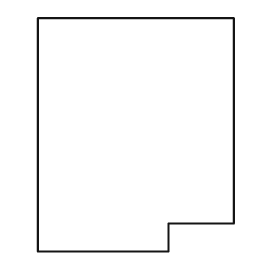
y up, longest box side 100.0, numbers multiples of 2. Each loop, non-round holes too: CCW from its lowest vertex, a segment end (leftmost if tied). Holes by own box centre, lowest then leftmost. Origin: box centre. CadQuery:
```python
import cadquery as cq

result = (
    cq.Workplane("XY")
    .moveTo(-42.0, -50.0)
    .lineTo(14.0, -50.0)
    .lineTo(14.0, -38.0)
    .lineTo(42.0, -38.0)
    .lineTo(42.0, 50.0)
    .lineTo(-42.0, 50.0)
    .close()
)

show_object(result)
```